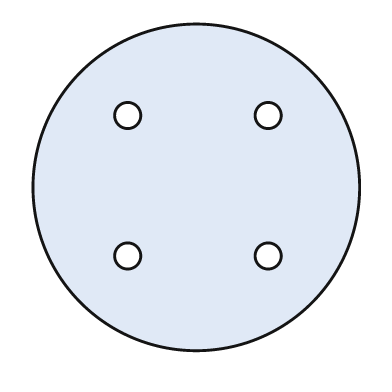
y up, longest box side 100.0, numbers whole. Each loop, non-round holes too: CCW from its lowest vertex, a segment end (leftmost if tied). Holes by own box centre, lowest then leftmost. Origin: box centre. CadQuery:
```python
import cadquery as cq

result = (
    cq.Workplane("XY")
    .moveTo(0.0, 0.0)
    .circle(50.0)
    .moveTo(-21.0, -21.0)
    .circle(4.0)
    .moveTo(22.0, -21.0)
    .circle(4.0)
    .moveTo(-21.0, 22.0)
    .circle(4.0)
    .moveTo(22.0, 22.0)
    .circle(4.0)
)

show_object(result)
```